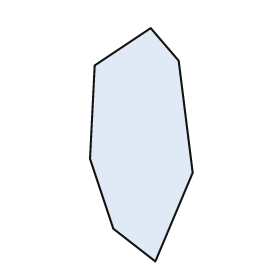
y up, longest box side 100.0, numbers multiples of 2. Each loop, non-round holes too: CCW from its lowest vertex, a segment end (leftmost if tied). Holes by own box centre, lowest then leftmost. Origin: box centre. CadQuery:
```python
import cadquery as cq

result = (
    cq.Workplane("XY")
    .moveTo(6.0, -50.0)
    .lineTo(22.0, -12.0)
    .lineTo(16.0, 36.0)
    .lineTo(4.0, 50.0)
    .lineTo(-20.0, 34.0)
    .lineTo(-22.0, -6.0)
    .lineTo(-12.0, -36.0)
    .close()
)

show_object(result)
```